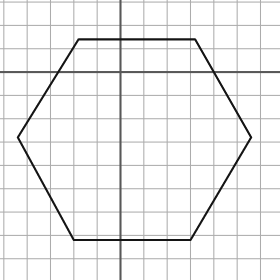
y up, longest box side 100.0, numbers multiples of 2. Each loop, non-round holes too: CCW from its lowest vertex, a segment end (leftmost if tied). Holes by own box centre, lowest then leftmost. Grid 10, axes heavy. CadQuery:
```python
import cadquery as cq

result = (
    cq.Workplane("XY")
    .moveTo(-20.0, -72.0)
    .lineTo(30.0, -72.0)
    .lineTo(56.0, -28.0)
    .lineTo(32.0, 14.0)
    .lineTo(-18.0, 14.0)
    .lineTo(-44.0, -28.0)
    .close()
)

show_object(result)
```